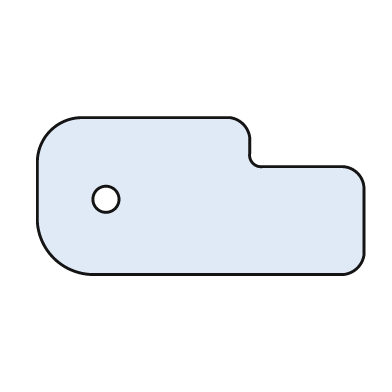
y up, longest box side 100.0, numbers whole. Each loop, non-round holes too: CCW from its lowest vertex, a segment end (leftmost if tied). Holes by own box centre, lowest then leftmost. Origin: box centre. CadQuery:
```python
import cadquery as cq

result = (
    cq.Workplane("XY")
    .moveTo(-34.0, -24.0)
    .lineTo(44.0, -24.0)
    .threePointArc((48.0, -22.0), (50.0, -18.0))
    .lineTo(50.0, 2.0)
    .threePointArc((48.0, 7.0), (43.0, 9.0))
    .lineTo(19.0, 9.0)
    .threePointArc((16.0, 10.0), (15.0, 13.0))
    .lineTo(15.0, 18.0)
    .threePointArc((13.0, 22.0), (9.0, 24.0))
    .lineTo(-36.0, 24.0)
    .threePointArc((-46.0, 20.0), (-50.0, 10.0))
    .lineTo(-50.0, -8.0)
    .threePointArc((-45.0, -19.0), (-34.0, -24.0))
    .close()
    .moveTo(-29.0, -1.0)
    .circle(4.0)
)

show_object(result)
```